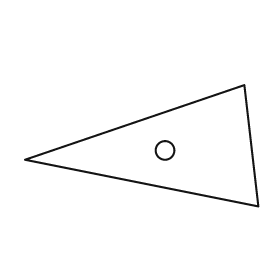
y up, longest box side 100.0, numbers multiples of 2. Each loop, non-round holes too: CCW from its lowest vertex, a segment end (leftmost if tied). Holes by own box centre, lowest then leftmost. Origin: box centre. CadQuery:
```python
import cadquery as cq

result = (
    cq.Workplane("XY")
    .moveTo(50.0, -26.0)
    .lineTo(44.0, 26.0)
    .lineTo(-50.0, -6.0)
    .close()
    .moveTo(10.0, -2.0)
    .circle(4.0)
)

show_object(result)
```